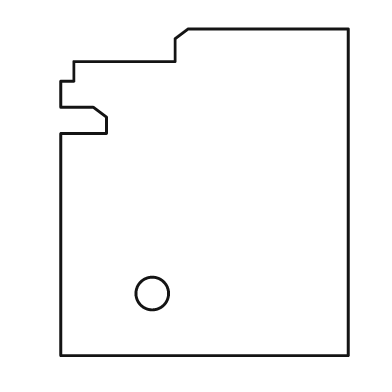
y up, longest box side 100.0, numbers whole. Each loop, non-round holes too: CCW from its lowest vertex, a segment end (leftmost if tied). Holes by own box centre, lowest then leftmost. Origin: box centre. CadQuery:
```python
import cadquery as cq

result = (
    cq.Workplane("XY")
    .moveTo(-44.0, -50.0)
    .lineTo(44.0, -50.0)
    .lineTo(44.0, 50.0)
    .lineTo(-5.0, 50.0)
    .lineTo(-9.0, 47.0)
    .lineTo(-9.0, 40.0)
    .lineTo(-40.0, 40.0)
    .lineTo(-40.0, 34.0)
    .lineTo(-44.0, 34.0)
    .lineTo(-44.0, 26.0)
    .lineTo(-34.0, 26.0)
    .lineTo(-30.0, 23.0)
    .lineTo(-30.0, 18.0)
    .lineTo(-44.0, 18.0)
    .close()
    .moveTo(-16.0, -31.0)
    .circle(5.0)
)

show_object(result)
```